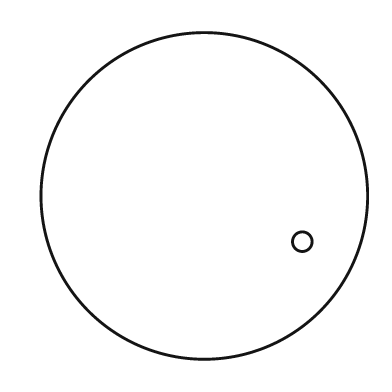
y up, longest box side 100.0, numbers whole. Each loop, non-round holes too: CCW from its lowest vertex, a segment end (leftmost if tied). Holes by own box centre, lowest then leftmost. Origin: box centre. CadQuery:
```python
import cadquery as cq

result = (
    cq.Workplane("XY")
    .moveTo(0.0, 0.0)
    .circle(50.0)
    .moveTo(30.0, -14.0)
    .circle(3.0)
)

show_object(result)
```